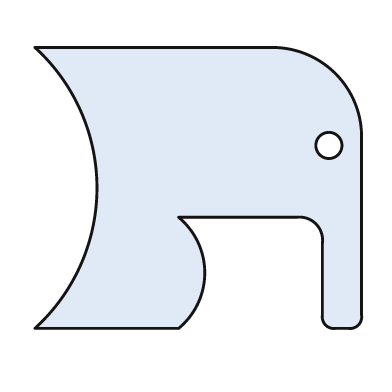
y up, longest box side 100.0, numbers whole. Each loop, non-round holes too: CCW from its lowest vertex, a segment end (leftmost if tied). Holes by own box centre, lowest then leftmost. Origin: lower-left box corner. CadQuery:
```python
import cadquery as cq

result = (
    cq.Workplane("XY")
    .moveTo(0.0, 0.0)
    .lineTo(44.0, 0.0)
    .threePointArc((52.0, 17.0), (44.0, 34.0))
    .lineTo(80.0, 34.0)
    .threePointArc((86.0, 32.0), (88.0, 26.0))
    .lineTo(88.0, 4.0)
    .threePointArc((89.0, 1.0), (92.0, 0.0))
    .lineTo(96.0, 0.0)
    .threePointArc((99.0, 1.0), (100.0, 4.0))
    .lineTo(100.0, 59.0)
    .threePointArc((92.0, 78.0), (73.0, 86.0))
    .lineTo(0.0, 86.0)
    .threePointArc((19.0, 43.0), (0.0, 0.0))
    .close()
    .moveTo(90.0, 56.0)
    .circle(4.0)
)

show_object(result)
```